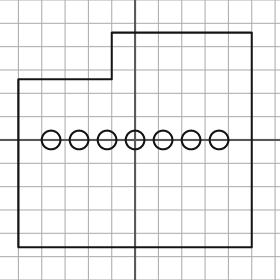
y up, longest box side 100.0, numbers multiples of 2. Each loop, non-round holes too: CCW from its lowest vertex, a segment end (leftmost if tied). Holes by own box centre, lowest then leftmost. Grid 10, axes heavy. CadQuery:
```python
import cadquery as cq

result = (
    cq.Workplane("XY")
    .moveTo(-50.0, -46.0)
    .lineTo(50.0, -46.0)
    .lineTo(50.0, 46.0)
    .lineTo(-10.0, 46.0)
    .lineTo(-10.0, 26.0)
    .lineTo(-50.0, 26.0)
    .close()
    .moveTo(-36.0, 0.0)
    .circle(4.0)
    .moveTo(-24.0, 0.0)
    .circle(4.0)
    .moveTo(-12.0, 0.0)
    .circle(4.0)
    .moveTo(0.0, 0.0)
    .circle(4.0)
    .moveTo(12.0, 0.0)
    .circle(4.0)
    .moveTo(24.0, 0.0)
    .circle(4.0)
    .moveTo(36.0, 0.0)
    .circle(4.0)
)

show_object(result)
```